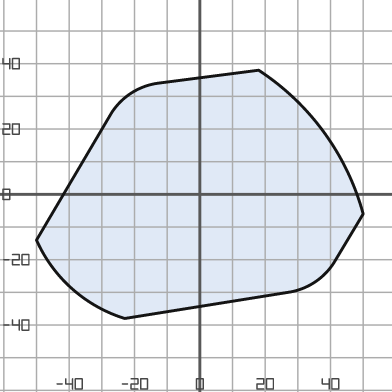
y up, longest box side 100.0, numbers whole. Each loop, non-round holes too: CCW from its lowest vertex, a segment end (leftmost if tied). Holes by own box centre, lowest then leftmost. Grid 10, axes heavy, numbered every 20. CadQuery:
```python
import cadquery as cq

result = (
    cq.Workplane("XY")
    .moveTo(-23.0, -38.0)
    .lineTo(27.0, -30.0)
    .threePointArc((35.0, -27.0), (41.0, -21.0))
    .lineTo(50.0, -6.0)
    .threePointArc((38.0, 19.0), (18.0, 38.0))
    .lineTo(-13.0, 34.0)
    .threePointArc((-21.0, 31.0), (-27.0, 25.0))
    .lineTo(-50.0, -14.0)
    .threePointArc((-39.0, -29.0), (-23.0, -38.0))
    .close()
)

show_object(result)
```